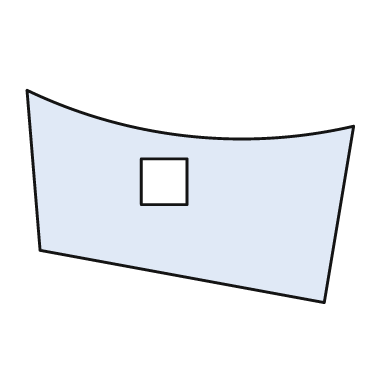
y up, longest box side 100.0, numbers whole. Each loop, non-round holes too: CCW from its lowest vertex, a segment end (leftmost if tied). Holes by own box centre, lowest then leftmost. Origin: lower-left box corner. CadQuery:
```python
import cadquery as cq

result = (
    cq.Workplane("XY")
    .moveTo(91.0, 0.0)
    .lineTo(100.0, 54.0)
    .threePointArc((49.0, 51.0), (0.0, 65.0))
    .lineTo(4.0, 16.0)
    .close()
    .moveTo(35.0, 30.0)
    .lineTo(49.0, 30.0)
    .lineTo(49.0, 44.0)
    .lineTo(35.0, 44.0)
    .close()
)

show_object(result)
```